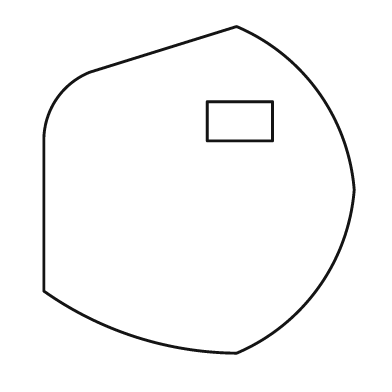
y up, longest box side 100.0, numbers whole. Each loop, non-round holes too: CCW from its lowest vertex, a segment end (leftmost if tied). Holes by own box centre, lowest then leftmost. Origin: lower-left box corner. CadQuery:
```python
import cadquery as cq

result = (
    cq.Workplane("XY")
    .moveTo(59.0, 0.0)
    .threePointArc((84.0, 20.0), (95.0, 50.0))
    .threePointArc((84.0, 80.0), (59.0, 100.0))
    .lineTo(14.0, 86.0)
    .threePointArc((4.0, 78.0), (0.0, 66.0))
    .lineTo(0.0, 19.0)
    .threePointArc((28.0, 5.0), (59.0, 0.0))
    .close()
    .moveTo(50.0, 65.0)
    .lineTo(70.0, 65.0)
    .lineTo(70.0, 77.0)
    .lineTo(50.0, 77.0)
    .close()
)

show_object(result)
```